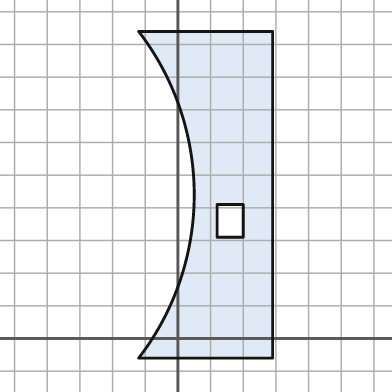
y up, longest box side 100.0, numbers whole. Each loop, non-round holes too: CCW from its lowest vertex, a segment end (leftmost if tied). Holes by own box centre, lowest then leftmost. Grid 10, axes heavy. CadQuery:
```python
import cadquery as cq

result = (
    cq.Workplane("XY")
    .moveTo(-12.0, -6.0)
    .lineTo(29.0, -6.0)
    .lineTo(29.0, 94.0)
    .lineTo(-12.0, 94.0)
    .threePointArc((5.0, 44.0), (-12.0, -6.0))
    .close()
    .moveTo(12.0, 31.0)
    .lineTo(20.0, 31.0)
    .lineTo(20.0, 41.0)
    .lineTo(12.0, 41.0)
    .close()
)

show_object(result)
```